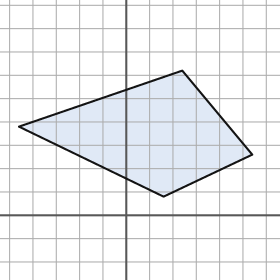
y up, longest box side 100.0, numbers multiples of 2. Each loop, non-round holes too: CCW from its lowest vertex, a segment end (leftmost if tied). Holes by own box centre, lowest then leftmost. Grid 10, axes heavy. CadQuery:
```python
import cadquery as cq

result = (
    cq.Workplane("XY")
    .moveTo(16.0, 8.0)
    .lineTo(54.0, 26.0)
    .lineTo(24.0, 62.0)
    .lineTo(-46.0, 38.0)
    .close()
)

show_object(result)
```